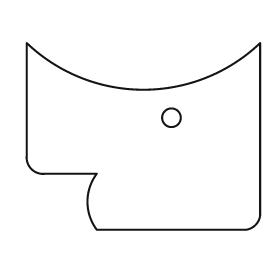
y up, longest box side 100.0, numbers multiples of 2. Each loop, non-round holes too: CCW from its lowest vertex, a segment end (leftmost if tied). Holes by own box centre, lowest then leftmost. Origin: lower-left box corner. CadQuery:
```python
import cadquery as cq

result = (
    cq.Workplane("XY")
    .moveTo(30.0, 0.0)
    .lineTo(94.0, 0.0)
    .threePointArc((98.0, 2.0), (100.0, 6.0))
    .lineTo(100.0, 80.0)
    .threePointArc((50.0, 60.0), (0.0, 80.0))
    .lineTo(0.0, 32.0)
    .threePointArc((2.0, 26.0), (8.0, 24.0))
    .lineTo(30.0, 24.0)
    .threePointArc((26.0, 12.0), (30.0, 0.0))
    .close()
    .moveTo(62.0, 48.0)
    .circle(4.0)
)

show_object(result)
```